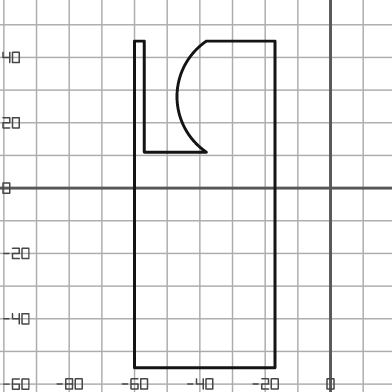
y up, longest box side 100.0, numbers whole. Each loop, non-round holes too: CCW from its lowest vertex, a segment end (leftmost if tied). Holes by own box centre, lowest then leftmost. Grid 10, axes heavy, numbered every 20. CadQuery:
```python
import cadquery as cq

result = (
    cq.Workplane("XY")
    .moveTo(-60.0, -55.0)
    .lineTo(-17.0, -55.0)
    .lineTo(-17.0, 45.0)
    .lineTo(-38.0, 45.0)
    .threePointArc((-47.0, 28.0), (-38.0, 11.0))
    .lineTo(-57.0, 11.0)
    .lineTo(-57.0, 45.0)
    .lineTo(-60.0, 45.0)
    .close()
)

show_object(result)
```